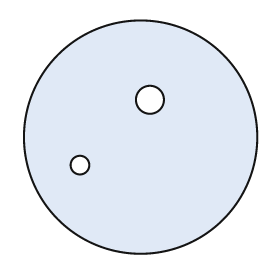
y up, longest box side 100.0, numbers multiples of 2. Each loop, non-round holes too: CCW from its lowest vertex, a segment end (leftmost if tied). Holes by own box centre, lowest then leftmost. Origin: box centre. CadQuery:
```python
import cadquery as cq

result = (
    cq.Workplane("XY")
    .moveTo(0.0, 0.0)
    .circle(50.0)
    .moveTo(-26.0, -12.0)
    .circle(4.0)
    .moveTo(4.0, 16.0)
    .circle(6.0)
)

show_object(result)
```